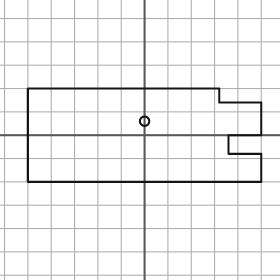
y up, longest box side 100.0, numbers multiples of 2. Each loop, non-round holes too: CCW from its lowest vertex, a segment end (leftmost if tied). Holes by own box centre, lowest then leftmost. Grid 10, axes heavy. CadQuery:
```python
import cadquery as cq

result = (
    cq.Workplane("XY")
    .moveTo(-50.0, -20.0)
    .lineTo(50.0, -20.0)
    .lineTo(50.0, -8.0)
    .lineTo(36.0, -8.0)
    .lineTo(36.0, 0.0)
    .lineTo(50.0, 0.0)
    .lineTo(50.0, 14.0)
    .lineTo(32.0, 14.0)
    .lineTo(32.0, 20.0)
    .lineTo(-50.0, 20.0)
    .close()
    .moveTo(0.0, 6.0)
    .circle(2.0)
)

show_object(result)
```